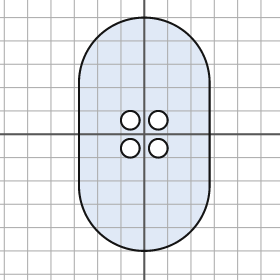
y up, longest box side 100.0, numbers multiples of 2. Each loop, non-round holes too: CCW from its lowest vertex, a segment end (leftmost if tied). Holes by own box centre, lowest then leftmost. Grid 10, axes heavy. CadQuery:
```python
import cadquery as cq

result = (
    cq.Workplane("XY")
    .moveTo(-28.0, -22.0)
    .threePointArc((0.0, -50.0), (28.0, -22.0))
    .lineTo(28.0, 22.0)
    .threePointArc((0.0, 50.0), (-28.0, 22.0))
    .close()
    .moveTo(-6.0, -6.0)
    .circle(4.0)
    .moveTo(6.0, -6.0)
    .circle(4.0)
    .moveTo(-6.0, 6.0)
    .circle(4.0)
    .moveTo(6.0, 6.0)
    .circle(4.0)
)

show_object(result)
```